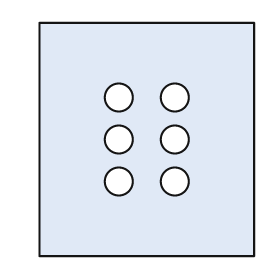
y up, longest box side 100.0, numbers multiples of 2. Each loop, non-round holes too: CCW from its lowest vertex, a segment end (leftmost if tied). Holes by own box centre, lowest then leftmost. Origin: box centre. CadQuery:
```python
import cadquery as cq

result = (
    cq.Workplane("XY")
    .moveTo(-46.0, -50.0)
    .lineTo(46.0, -50.0)
    .lineTo(46.0, 50.0)
    .lineTo(-46.0, 50.0)
    .close()
    .moveTo(-12.0, -18.0)
    .circle(6.0)
    .moveTo(12.0, -18.0)
    .circle(6.0)
    .moveTo(-12.0, 0.0)
    .circle(6.0)
    .moveTo(12.0, 0.0)
    .circle(6.0)
    .moveTo(-12.0, 18.0)
    .circle(6.0)
    .moveTo(12.0, 18.0)
    .circle(6.0)
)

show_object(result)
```